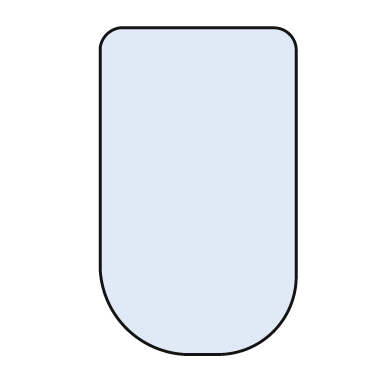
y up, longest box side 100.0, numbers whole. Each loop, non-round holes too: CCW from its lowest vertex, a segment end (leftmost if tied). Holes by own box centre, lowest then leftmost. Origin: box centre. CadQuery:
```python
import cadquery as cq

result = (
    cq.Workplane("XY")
    .moveTo(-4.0, -50.0)
    .lineTo(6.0, -50.0)
    .threePointArc((23.0, -43.0), (30.0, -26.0))
    .lineTo(30.0, 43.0)
    .threePointArc((28.0, 48.0), (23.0, 50.0))
    .lineTo(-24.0, 50.0)
    .threePointArc((-28.0, 48.0), (-30.0, 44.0))
    .lineTo(-30.0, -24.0)
    .threePointArc((-22.0, -42.0), (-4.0, -50.0))
    .close()
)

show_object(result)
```